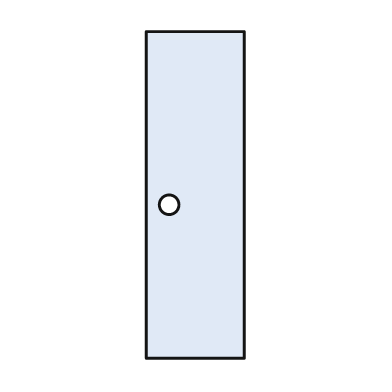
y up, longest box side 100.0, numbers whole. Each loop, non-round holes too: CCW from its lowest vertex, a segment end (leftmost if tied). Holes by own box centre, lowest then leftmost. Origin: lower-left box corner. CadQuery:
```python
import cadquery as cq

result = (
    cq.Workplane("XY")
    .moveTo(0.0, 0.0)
    .lineTo(30.0, 0.0)
    .lineTo(30.0, 100.0)
    .lineTo(0.0, 100.0)
    .close()
    .moveTo(7.0, 47.0)
    .circle(3.0)
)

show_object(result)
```